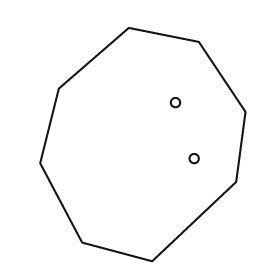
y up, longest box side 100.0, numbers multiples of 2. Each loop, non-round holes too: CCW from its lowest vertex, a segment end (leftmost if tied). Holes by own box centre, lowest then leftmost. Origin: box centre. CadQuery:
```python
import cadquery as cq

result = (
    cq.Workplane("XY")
    .moveTo(4.0, -50.0)
    .lineTo(40.0, -16.0)
    .lineTo(44.0, 14.0)
    .lineTo(24.0, 44.0)
    .lineTo(-6.0, 50.0)
    .lineTo(-36.0, 24.0)
    .lineTo(-44.0, -8.0)
    .lineTo(-26.0, -42.0)
    .close()
    .moveTo(22.0, -6.0)
    .circle(2.0)
    .moveTo(14.0, 18.0)
    .circle(2.0)
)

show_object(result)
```